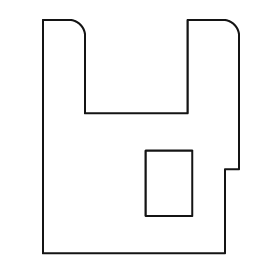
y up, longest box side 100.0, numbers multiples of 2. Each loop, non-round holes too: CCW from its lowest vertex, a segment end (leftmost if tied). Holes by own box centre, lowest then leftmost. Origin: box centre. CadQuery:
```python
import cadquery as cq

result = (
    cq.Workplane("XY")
    .moveTo(-42.0, -50.0)
    .lineTo(36.0, -50.0)
    .lineTo(36.0, -14.0)
    .lineTo(42.0, -14.0)
    .lineTo(42.0, 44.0)
    .threePointArc((40.0, 48.0), (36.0, 50.0))
    .lineTo(20.0, 50.0)
    .lineTo(20.0, 10.0)
    .lineTo(-24.0, 10.0)
    .lineTo(-24.0, 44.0)
    .threePointArc((-26.0, 48.0), (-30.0, 50.0))
    .lineTo(-42.0, 50.0)
    .close()
    .moveTo(2.0, -34.0)
    .lineTo(22.0, -34.0)
    .lineTo(22.0, -6.0)
    .lineTo(2.0, -6.0)
    .close()
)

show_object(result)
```